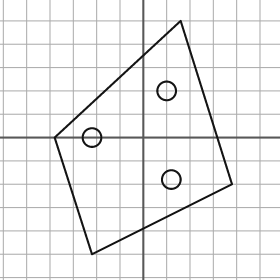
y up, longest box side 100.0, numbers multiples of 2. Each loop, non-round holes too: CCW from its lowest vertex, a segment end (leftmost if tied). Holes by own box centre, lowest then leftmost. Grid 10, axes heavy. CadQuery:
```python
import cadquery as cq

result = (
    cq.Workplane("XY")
    .moveTo(-22.0, -50.0)
    .lineTo(38.0, -20.0)
    .lineTo(16.0, 50.0)
    .lineTo(-38.0, 0.0)
    .close()
    .moveTo(12.0, -18.0)
    .circle(4.0)
    .moveTo(-22.0, 0.0)
    .circle(4.0)
    .moveTo(10.0, 20.0)
    .circle(4.0)
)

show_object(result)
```